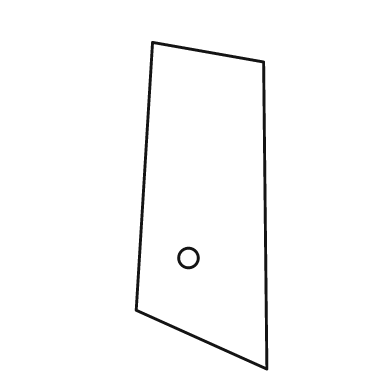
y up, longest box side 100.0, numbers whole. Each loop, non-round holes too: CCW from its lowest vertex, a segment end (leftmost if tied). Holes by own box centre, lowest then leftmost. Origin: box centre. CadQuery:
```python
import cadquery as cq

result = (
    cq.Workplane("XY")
    .moveTo(20.0, -50.0)
    .lineTo(19.0, 44.0)
    .lineTo(-15.0, 50.0)
    .lineTo(-20.0, -32.0)
    .close()
    .moveTo(-4.0, -16.0)
    .circle(3.0)
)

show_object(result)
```